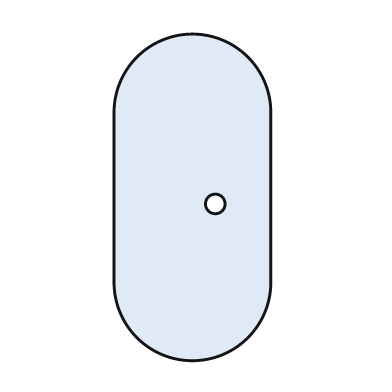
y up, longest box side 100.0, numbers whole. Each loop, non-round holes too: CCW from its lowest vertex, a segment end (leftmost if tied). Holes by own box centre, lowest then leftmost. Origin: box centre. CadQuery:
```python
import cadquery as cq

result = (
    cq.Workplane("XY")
    .moveTo(-24.0, -26.0)
    .threePointArc((0.0, -50.0), (24.0, -26.0))
    .lineTo(24.0, 26.0)
    .threePointArc((0.0, 50.0), (-24.0, 26.0))
    .close()
    .moveTo(7.0, -2.0)
    .circle(3.0)
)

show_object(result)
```